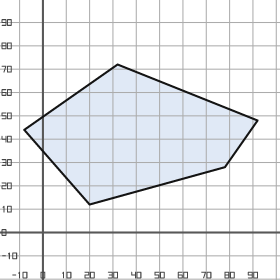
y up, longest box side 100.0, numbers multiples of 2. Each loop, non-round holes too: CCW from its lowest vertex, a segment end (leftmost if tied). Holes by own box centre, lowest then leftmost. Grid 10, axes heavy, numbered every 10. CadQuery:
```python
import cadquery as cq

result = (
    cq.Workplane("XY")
    .moveTo(20.0, 12.0)
    .lineTo(78.0, 28.0)
    .lineTo(92.0, 48.0)
    .lineTo(32.0, 72.0)
    .lineTo(-8.0, 44.0)
    .close()
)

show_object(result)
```